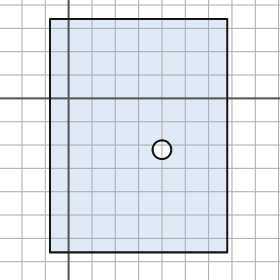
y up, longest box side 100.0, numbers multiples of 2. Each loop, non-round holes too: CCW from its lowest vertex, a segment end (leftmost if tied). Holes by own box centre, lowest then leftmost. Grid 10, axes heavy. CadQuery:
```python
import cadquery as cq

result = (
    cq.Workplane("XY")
    .moveTo(-8.0, -66.0)
    .lineTo(68.0, -66.0)
    .lineTo(68.0, 34.0)
    .lineTo(-8.0, 34.0)
    .close()
    .moveTo(40.0, -22.0)
    .circle(4.0)
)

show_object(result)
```